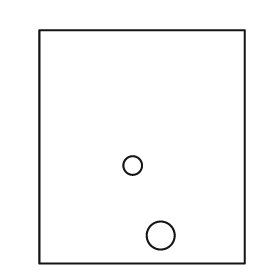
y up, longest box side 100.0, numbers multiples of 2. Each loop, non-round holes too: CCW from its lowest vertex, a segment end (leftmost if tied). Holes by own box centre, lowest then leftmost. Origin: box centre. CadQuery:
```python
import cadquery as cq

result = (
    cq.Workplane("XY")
    .moveTo(-44.0, -50.0)
    .lineTo(44.0, -50.0)
    .lineTo(44.0, 50.0)
    .lineTo(-44.0, 50.0)
    .close()
    .moveTo(8.0, -38.0)
    .circle(6.0)
    .moveTo(-4.0, -8.0)
    .circle(4.0)
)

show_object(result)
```